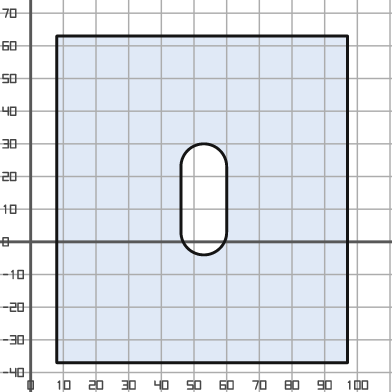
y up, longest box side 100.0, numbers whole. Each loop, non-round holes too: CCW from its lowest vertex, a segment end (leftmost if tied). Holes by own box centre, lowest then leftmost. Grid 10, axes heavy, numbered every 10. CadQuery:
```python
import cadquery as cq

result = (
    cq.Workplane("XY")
    .moveTo(8.0, -37.0)
    .lineTo(97.0, -37.0)
    .lineTo(97.0, 63.0)
    .lineTo(8.0, 63.0)
    .close()
    .moveTo(46.0, 3.0)
    .threePointArc((53.0, -4.0), (60.0, 3.0))
    .lineTo(60.0, 23.0)
    .threePointArc((53.0, 30.0), (46.0, 23.0))
    .close()
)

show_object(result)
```